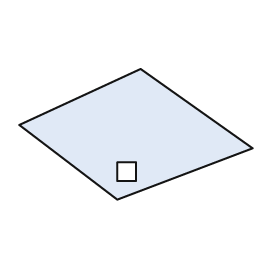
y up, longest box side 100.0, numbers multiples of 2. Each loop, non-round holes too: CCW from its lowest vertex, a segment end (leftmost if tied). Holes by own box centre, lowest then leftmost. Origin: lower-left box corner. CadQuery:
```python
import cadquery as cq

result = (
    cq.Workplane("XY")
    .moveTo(42.0, 0.0)
    .lineTo(100.0, 22.0)
    .lineTo(52.0, 56.0)
    .lineTo(0.0, 32.0)
    .close()
    .moveTo(42.0, 8.0)
    .lineTo(50.0, 8.0)
    .lineTo(50.0, 16.0)
    .lineTo(42.0, 16.0)
    .close()
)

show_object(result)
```